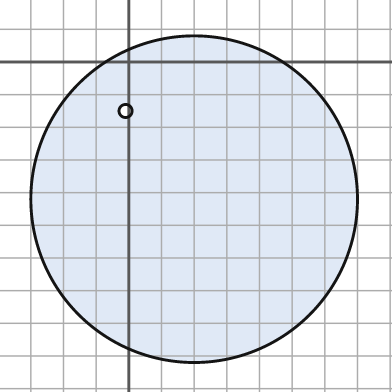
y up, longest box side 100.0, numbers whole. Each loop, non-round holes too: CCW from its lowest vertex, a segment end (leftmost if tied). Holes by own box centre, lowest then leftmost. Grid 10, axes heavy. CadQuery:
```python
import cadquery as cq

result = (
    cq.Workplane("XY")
    .moveTo(20.0, -42.0)
    .circle(50.0)
    .moveTo(-1.0, -15.0)
    .circle(2.0)
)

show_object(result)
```